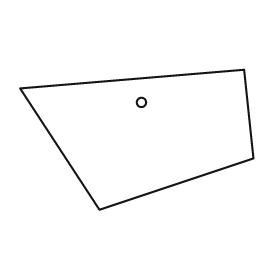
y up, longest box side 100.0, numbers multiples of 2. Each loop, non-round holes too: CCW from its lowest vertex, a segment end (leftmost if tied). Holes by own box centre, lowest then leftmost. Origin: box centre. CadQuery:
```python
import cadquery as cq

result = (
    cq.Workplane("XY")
    .moveTo(-16.0, -30.0)
    .lineTo(50.0, -8.0)
    .lineTo(46.0, 30.0)
    .lineTo(-50.0, 22.0)
    .close()
    .moveTo(2.0, 16.0)
    .circle(2.0)
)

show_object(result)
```